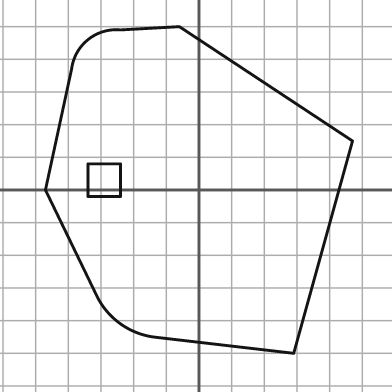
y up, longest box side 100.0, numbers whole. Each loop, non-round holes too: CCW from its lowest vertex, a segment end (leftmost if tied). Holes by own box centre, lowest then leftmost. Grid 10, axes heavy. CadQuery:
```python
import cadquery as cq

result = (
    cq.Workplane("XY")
    .moveTo(29.0, -50.0)
    .lineTo(47.0, 15.0)
    .lineTo(-6.0, 50.0)
    .lineTo(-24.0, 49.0)
    .threePointArc((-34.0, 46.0), (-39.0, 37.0))
    .lineTo(-47.0, 0.0)
    .lineTo(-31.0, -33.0)
    .threePointArc((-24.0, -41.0), (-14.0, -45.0))
    .close()
    .moveTo(-34.0, -2.0)
    .lineTo(-24.0, -2.0)
    .lineTo(-24.0, 8.0)
    .lineTo(-34.0, 8.0)
    .close()
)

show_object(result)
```